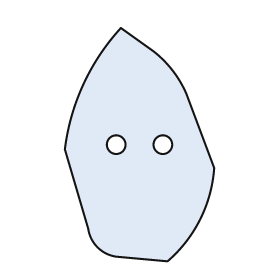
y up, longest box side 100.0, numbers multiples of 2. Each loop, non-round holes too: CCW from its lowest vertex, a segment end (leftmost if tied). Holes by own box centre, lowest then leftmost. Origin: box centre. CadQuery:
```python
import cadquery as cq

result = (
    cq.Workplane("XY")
    .moveTo(12.0, -50.0)
    .threePointArc((26.0, -32.0), (32.0, -10.0))
    .lineTo(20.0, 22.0)
    .threePointArc((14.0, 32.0), (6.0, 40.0))
    .lineTo(-8.0, 50.0)
    .threePointArc((-24.0, 26.0), (-32.0, -2.0))
    .lineTo(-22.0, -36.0)
    .threePointArc((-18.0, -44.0), (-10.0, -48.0))
    .close()
    .moveTo(-10.0, 0.0)
    .circle(4.0)
    .moveTo(10.0, 0.0)
    .circle(4.0)
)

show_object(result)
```